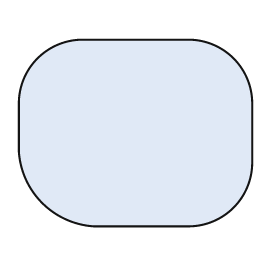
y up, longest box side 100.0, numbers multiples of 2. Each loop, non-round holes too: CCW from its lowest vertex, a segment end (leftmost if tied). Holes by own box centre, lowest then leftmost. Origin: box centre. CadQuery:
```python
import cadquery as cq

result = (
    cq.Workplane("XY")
    .moveTo(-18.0, -40.0)
    .lineTo(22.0, -40.0)
    .threePointArc((42.0, -32.0), (50.0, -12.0))
    .lineTo(50.0, 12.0)
    .threePointArc((42.0, 32.0), (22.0, 40.0))
    .lineTo(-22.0, 40.0)
    .threePointArc((-42.0, 32.0), (-50.0, 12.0))
    .lineTo(-50.0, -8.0)
    .threePointArc((-40.0, -30.0), (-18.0, -40.0))
    .close()
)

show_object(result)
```